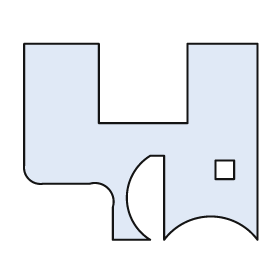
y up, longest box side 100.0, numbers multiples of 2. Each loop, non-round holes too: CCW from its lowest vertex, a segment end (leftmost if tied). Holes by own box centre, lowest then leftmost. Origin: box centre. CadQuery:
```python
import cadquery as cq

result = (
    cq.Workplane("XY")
    .moveTo(-12.0, -42.0)
    .lineTo(4.0, -42.0)
    .threePointArc((-6.0, -24.0), (4.0, -6.0))
    .lineTo(10.0, -6.0)
    .lineTo(10.0, -42.0)
    .threePointArc((30.0, -32.0), (50.0, -42.0))
    .lineTo(50.0, 42.0)
    .lineTo(20.0, 42.0)
    .lineTo(20.0, 8.0)
    .lineTo(-18.0, 8.0)
    .lineTo(-18.0, 42.0)
    .lineTo(-50.0, 42.0)
    .lineTo(-50.0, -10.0)
    .threePointArc((-48.0, -16.0), (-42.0, -18.0))
    .lineTo(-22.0, -18.0)
    .threePointArc((-14.0, -20.0), (-12.0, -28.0))
    .close()
    .moveTo(32.0, -16.0)
    .lineTo(40.0, -16.0)
    .lineTo(40.0, -8.0)
    .lineTo(32.0, -8.0)
    .close()
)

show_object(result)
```